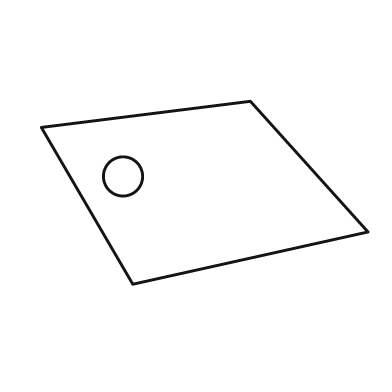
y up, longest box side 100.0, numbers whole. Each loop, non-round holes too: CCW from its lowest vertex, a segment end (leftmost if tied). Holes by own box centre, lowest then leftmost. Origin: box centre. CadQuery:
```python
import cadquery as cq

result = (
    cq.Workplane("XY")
    .moveTo(-22.0, -28.0)
    .lineTo(50.0, -12.0)
    .lineTo(14.0, 28.0)
    .lineTo(-50.0, 20.0)
    .close()
    .moveTo(-25.0, 5.0)
    .circle(6.0)
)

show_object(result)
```